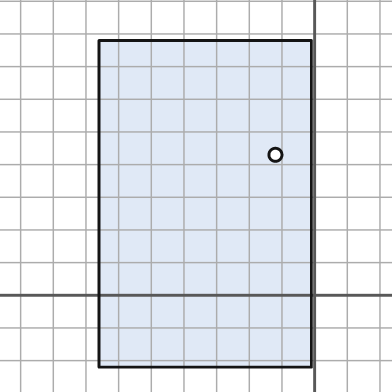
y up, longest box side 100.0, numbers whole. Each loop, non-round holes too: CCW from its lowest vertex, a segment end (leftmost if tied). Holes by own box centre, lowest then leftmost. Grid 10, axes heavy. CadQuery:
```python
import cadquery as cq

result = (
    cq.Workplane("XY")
    .moveTo(-66.0, -22.0)
    .lineTo(-1.0, -22.0)
    .lineTo(-1.0, 78.0)
    .lineTo(-66.0, 78.0)
    .close()
    .moveTo(-12.0, 43.0)
    .circle(2.0)
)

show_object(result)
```